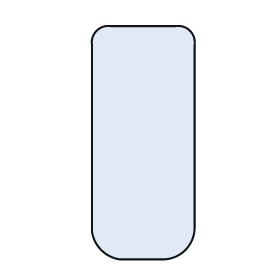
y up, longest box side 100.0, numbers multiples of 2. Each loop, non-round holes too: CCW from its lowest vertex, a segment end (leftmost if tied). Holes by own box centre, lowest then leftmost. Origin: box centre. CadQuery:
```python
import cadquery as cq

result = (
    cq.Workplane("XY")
    .moveTo(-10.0, -50.0)
    .lineTo(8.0, -50.0)
    .threePointArc((18.0, -46.0), (22.0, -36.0))
    .lineTo(22.0, 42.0)
    .threePointArc((20.0, 48.0), (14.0, 50.0))
    .lineTo(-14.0, 50.0)
    .threePointArc((-20.0, 48.0), (-22.0, 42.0))
    .lineTo(-22.0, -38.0)
    .threePointArc((-18.0, -46.0), (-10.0, -50.0))
    .close()
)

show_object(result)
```